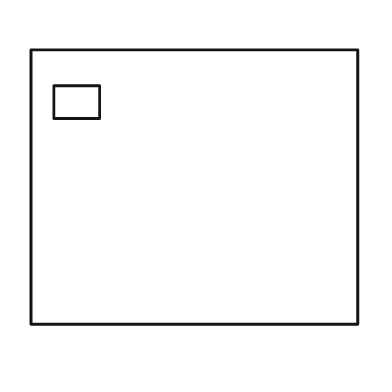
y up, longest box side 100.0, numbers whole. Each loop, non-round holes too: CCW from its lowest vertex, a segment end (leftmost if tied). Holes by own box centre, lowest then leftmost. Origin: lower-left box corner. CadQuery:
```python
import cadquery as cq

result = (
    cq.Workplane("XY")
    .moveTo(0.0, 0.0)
    .lineTo(100.0, 0.0)
    .lineTo(100.0, 84.0)
    .lineTo(0.0, 84.0)
    .close()
    .moveTo(7.0, 63.0)
    .lineTo(21.0, 63.0)
    .lineTo(21.0, 73.0)
    .lineTo(7.0, 73.0)
    .close()
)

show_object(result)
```